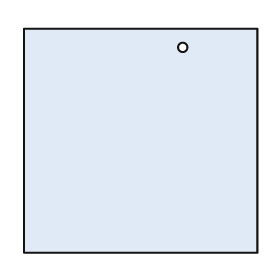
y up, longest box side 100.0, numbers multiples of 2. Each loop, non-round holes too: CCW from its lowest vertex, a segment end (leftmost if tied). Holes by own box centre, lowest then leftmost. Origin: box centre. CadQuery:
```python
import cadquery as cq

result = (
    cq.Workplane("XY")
    .moveTo(-50.0, -48.0)
    .lineTo(50.0, -48.0)
    .lineTo(50.0, 48.0)
    .lineTo(-50.0, 48.0)
    .close()
    .moveTo(18.0, 40.0)
    .circle(2.0)
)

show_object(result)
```